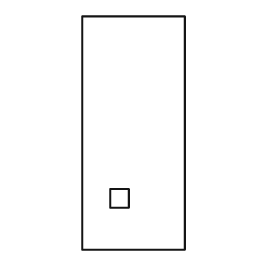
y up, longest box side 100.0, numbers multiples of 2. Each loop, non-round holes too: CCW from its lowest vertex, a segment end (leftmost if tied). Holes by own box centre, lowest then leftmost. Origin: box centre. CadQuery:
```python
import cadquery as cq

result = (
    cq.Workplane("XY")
    .moveTo(-22.0, -50.0)
    .lineTo(22.0, -50.0)
    .lineTo(22.0, 50.0)
    .lineTo(-22.0, 50.0)
    .close()
    .moveTo(-10.0, -32.0)
    .lineTo(-2.0, -32.0)
    .lineTo(-2.0, -24.0)
    .lineTo(-10.0, -24.0)
    .close()
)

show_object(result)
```